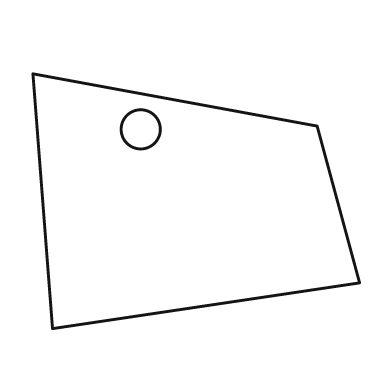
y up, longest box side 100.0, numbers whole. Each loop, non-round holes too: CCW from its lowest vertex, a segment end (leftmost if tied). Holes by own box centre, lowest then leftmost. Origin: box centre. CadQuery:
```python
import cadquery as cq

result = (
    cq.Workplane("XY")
    .moveTo(-44.0, -39.0)
    .lineTo(50.0, -25.0)
    .lineTo(37.0, 23.0)
    .lineTo(-50.0, 39.0)
    .close()
    .moveTo(-17.0, 22.0)
    .circle(6.0)
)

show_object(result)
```